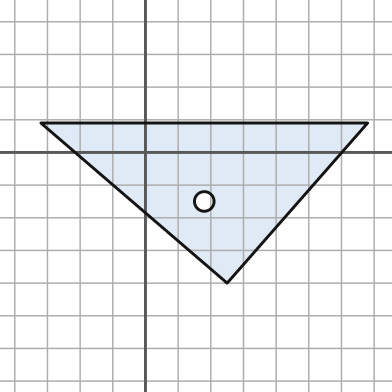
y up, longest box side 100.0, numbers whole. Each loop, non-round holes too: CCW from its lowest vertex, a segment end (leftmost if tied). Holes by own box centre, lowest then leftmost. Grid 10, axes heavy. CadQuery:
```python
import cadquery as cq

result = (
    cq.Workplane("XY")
    .moveTo(25.0, -40.0)
    .lineTo(68.0, 9.0)
    .lineTo(-32.0, 9.0)
    .close()
    .moveTo(18.0, -15.0)
    .circle(3.0)
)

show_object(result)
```